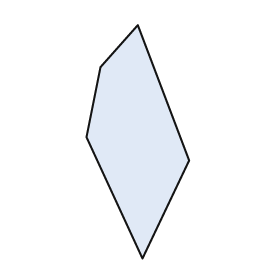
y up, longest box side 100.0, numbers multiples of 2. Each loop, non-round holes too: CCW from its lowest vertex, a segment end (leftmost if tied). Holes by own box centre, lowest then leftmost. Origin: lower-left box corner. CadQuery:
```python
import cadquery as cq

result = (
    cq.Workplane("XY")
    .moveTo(24.0, 0.0)
    .lineTo(44.0, 42.0)
    .lineTo(22.0, 100.0)
    .lineTo(6.0, 82.0)
    .lineTo(0.0, 52.0)
    .close()
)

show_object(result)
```